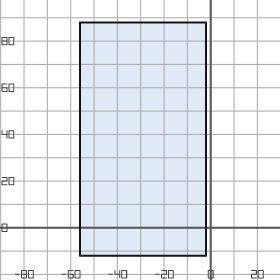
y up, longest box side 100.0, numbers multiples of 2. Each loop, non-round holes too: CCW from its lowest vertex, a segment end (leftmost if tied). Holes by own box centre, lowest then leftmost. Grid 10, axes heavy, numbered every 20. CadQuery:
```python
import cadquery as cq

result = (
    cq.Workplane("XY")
    .moveTo(-56.0, -12.0)
    .lineTo(-2.0, -12.0)
    .lineTo(-2.0, 88.0)
    .lineTo(-56.0, 88.0)
    .close()
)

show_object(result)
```